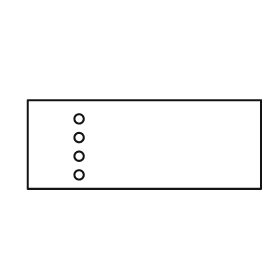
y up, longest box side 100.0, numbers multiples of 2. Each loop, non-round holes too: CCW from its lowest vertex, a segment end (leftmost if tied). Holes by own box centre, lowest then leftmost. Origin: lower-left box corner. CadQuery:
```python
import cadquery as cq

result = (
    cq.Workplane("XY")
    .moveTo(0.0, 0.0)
    .lineTo(100.0, 0.0)
    .lineTo(100.0, 38.0)
    .lineTo(0.0, 38.0)
    .close()
    .moveTo(22.0, 6.0)
    .circle(2.0)
    .moveTo(22.0, 14.0)
    .circle(2.0)
    .moveTo(22.0, 22.0)
    .circle(2.0)
    .moveTo(22.0, 30.0)
    .circle(2.0)
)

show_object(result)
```